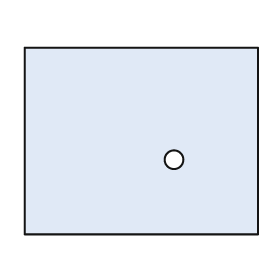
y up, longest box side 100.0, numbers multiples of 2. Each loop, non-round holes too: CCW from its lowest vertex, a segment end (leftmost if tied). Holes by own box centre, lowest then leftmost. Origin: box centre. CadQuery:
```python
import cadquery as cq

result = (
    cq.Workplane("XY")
    .moveTo(-50.0, -40.0)
    .lineTo(50.0, -40.0)
    .lineTo(50.0, 40.0)
    .lineTo(-50.0, 40.0)
    .close()
    .moveTo(14.0, -8.0)
    .circle(4.0)
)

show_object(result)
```